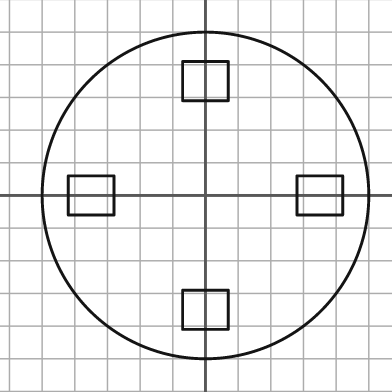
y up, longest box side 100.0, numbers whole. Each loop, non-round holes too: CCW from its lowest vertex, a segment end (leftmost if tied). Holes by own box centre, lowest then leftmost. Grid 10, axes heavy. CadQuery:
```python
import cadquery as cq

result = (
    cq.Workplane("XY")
    .moveTo(0.0, 0.0)
    .circle(50.0)
    .moveTo(-7.0, -41.0)
    .lineTo(7.0, -41.0)
    .lineTo(7.0, -29.0)
    .lineTo(-7.0, -29.0)
    .close()
    .moveTo(-42.0, -6.0)
    .lineTo(-28.0, -6.0)
    .lineTo(-28.0, 6.0)
    .lineTo(-42.0, 6.0)
    .close()
    .moveTo(28.0, -6.0)
    .lineTo(42.0, -6.0)
    .lineTo(42.0, 6.0)
    .lineTo(28.0, 6.0)
    .close()
    .moveTo(-7.0, 29.0)
    .lineTo(7.0, 29.0)
    .lineTo(7.0, 41.0)
    .lineTo(-7.0, 41.0)
    .close()
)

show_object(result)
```